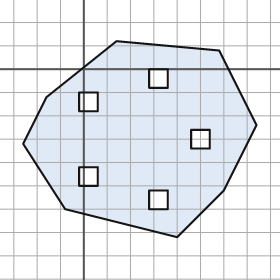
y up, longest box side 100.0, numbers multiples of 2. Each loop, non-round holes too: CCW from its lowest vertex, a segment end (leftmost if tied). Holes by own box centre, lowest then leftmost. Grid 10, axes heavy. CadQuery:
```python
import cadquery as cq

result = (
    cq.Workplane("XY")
    .moveTo(40.0, -72.0)
    .lineTo(60.0, -52.0)
    .lineTo(74.0, -24.0)
    .lineTo(58.0, 8.0)
    .lineTo(14.0, 12.0)
    .lineTo(-16.0, -12.0)
    .lineTo(-26.0, -32.0)
    .lineTo(-8.0, -60.0)
    .close()
    .moveTo(28.0, -60.0)
    .lineTo(36.0, -60.0)
    .lineTo(36.0, -52.0)
    .lineTo(28.0, -52.0)
    .close()
    .moveTo(-2.0, -50.0)
    .lineTo(6.0, -50.0)
    .lineTo(6.0, -42.0)
    .lineTo(-2.0, -42.0)
    .close()
    .moveTo(46.0, -34.0)
    .lineTo(54.0, -34.0)
    .lineTo(54.0, -26.0)
    .lineTo(46.0, -26.0)
    .close()
    .moveTo(-2.0, -18.0)
    .lineTo(6.0, -18.0)
    .lineTo(6.0, -10.0)
    .lineTo(-2.0, -10.0)
    .close()
    .moveTo(28.0, -8.0)
    .lineTo(36.0, -8.0)
    .lineTo(36.0, 0.0)
    .lineTo(28.0, 0.0)
    .close()
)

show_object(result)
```